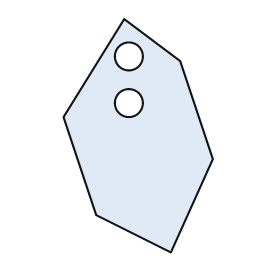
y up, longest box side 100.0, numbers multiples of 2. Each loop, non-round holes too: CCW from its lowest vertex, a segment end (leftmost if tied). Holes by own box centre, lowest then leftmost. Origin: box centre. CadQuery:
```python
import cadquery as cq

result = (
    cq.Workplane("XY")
    .moveTo(14.0, -50.0)
    .lineTo(32.0, -10.0)
    .lineTo(18.0, 32.0)
    .lineTo(-6.0, 50.0)
    .lineTo(-32.0, 8.0)
    .lineTo(-18.0, -34.0)
    .close()
    .moveTo(-4.0, 14.0)
    .circle(6.0)
    .moveTo(-4.0, 34.0)
    .circle(6.0)
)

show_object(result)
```